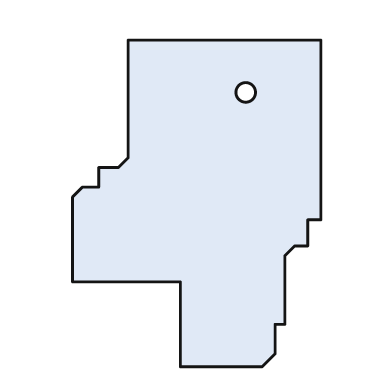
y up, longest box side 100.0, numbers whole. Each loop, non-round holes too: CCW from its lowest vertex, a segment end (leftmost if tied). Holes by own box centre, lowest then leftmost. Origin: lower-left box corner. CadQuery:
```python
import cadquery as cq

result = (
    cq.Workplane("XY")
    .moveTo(33.0, 0.0)
    .lineTo(58.0, 0.0)
    .lineTo(62.0, 4.0)
    .lineTo(62.0, 13.0)
    .lineTo(65.0, 13.0)
    .lineTo(65.0, 34.0)
    .lineTo(68.0, 37.0)
    .lineTo(72.0, 37.0)
    .lineTo(72.0, 45.0)
    .lineTo(76.0, 45.0)
    .lineTo(76.0, 100.0)
    .lineTo(17.0, 100.0)
    .lineTo(17.0, 64.0)
    .lineTo(14.0, 61.0)
    .lineTo(8.0, 61.0)
    .lineTo(8.0, 55.0)
    .lineTo(3.0, 55.0)
    .lineTo(0.0, 52.0)
    .lineTo(0.0, 26.0)
    .lineTo(33.0, 26.0)
    .close()
    .moveTo(53.0, 84.0)
    .circle(3.0)
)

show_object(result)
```